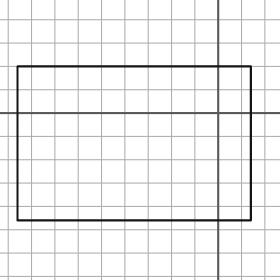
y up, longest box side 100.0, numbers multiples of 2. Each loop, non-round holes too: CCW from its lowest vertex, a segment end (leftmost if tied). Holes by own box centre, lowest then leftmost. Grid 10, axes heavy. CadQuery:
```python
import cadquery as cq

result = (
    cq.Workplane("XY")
    .moveTo(-86.0, -46.0)
    .lineTo(14.0, -46.0)
    .lineTo(14.0, 20.0)
    .lineTo(-86.0, 20.0)
    .close()
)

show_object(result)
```